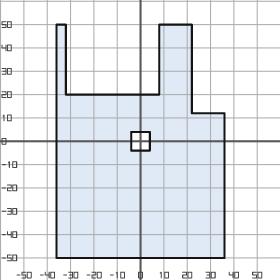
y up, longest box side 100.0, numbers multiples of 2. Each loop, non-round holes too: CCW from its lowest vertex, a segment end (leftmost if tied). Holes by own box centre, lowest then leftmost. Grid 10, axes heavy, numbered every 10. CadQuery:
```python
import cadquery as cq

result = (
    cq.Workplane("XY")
    .moveTo(-36.0, -50.0)
    .lineTo(36.0, -50.0)
    .lineTo(36.0, 12.0)
    .lineTo(22.0, 12.0)
    .lineTo(22.0, 50.0)
    .lineTo(8.0, 50.0)
    .lineTo(8.0, 20.0)
    .lineTo(-32.0, 20.0)
    .lineTo(-32.0, 50.0)
    .lineTo(-36.0, 50.0)
    .close()
    .moveTo(-4.0, -4.0)
    .lineTo(4.0, -4.0)
    .lineTo(4.0, 4.0)
    .lineTo(-4.0, 4.0)
    .close()
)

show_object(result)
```